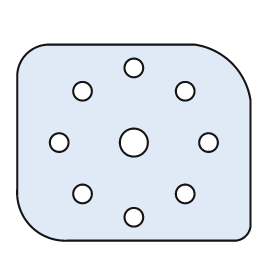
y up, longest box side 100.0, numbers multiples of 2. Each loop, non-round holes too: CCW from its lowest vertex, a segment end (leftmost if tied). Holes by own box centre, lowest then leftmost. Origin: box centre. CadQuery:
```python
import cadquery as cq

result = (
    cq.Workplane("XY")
    .moveTo(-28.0, -42.0)
    .lineTo(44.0, -42.0)
    .threePointArc((48.0, -40.0), (50.0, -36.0))
    .lineTo(50.0, 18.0)
    .threePointArc((42.0, 34.0), (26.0, 42.0))
    .lineTo(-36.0, 42.0)
    .threePointArc((-46.0, 38.0), (-50.0, 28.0))
    .lineTo(-50.0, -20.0)
    .threePointArc((-44.0, -36.0), (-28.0, -42.0))
    .close()
    .moveTo(0.0, -32.0)
    .circle(4.0)
    .moveTo(-22.0, -22.0)
    .circle(4.0)
    .moveTo(22.0, -22.0)
    .circle(4.0)
    .moveTo(-32.0, 0.0)
    .circle(4.0)
    .moveTo(0.0, 0.0)
    .circle(6.0)
    .moveTo(32.0, 0.0)
    .circle(4.0)
    .moveTo(-22.0, 22.0)
    .circle(4.0)
    .moveTo(22.0, 22.0)
    .circle(4.0)
    .moveTo(0.0, 32.0)
    .circle(4.0)
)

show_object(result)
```